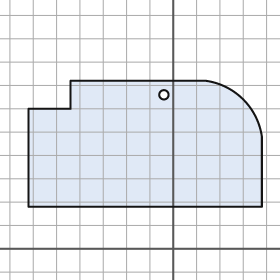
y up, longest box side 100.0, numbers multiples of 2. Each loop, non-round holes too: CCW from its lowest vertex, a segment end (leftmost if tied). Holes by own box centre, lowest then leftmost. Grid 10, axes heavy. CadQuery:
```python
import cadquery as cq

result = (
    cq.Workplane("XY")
    .moveTo(-62.0, 18.0)
    .lineTo(38.0, 18.0)
    .lineTo(38.0, 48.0)
    .threePointArc((30.0, 64.0), (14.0, 72.0))
    .lineTo(-44.0, 72.0)
    .lineTo(-44.0, 60.0)
    .lineTo(-62.0, 60.0)
    .close()
    .moveTo(-4.0, 66.0)
    .circle(2.0)
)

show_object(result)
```